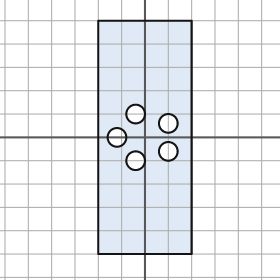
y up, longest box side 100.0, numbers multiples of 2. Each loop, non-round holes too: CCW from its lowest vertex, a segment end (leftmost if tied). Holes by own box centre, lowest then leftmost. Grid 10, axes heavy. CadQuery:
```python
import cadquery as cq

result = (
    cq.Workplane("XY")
    .moveTo(-20.0, -50.0)
    .lineTo(20.0, -50.0)
    .lineTo(20.0, 50.0)
    .lineTo(-20.0, 50.0)
    .close()
    .moveTo(-4.0, -10.0)
    .circle(4.0)
    .moveTo(10.0, -6.0)
    .circle(4.0)
    .moveTo(-12.0, 0.0)
    .circle(4.0)
    .moveTo(10.0, 6.0)
    .circle(4.0)
    .moveTo(-4.0, 10.0)
    .circle(4.0)
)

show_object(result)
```